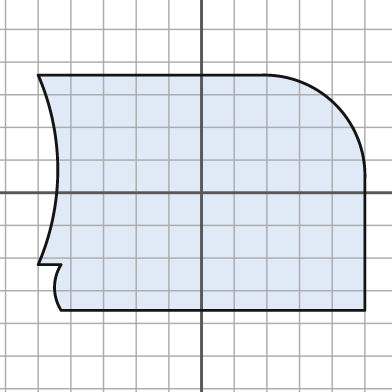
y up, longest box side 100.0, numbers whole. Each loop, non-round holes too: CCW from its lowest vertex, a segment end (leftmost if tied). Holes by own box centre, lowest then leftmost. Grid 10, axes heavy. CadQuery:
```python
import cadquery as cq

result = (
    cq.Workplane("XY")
    .moveTo(-43.0, -36.0)
    .lineTo(50.0, -36.0)
    .lineTo(50.0, 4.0)
    .threePointArc((41.0, 27.0), (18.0, 36.0))
    .lineTo(-50.0, 36.0)
    .threePointArc((-44.0, 7.0), (-50.0, -22.0))
    .lineTo(-43.0, -22.0)
    .threePointArc((-45.0, -29.0), (-43.0, -36.0))
    .close()
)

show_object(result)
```